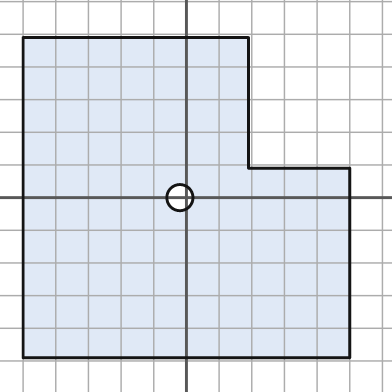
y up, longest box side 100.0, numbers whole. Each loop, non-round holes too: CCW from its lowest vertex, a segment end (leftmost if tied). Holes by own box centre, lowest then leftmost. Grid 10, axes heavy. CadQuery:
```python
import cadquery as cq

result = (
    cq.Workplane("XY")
    .moveTo(-50.0, -49.0)
    .lineTo(50.0, -49.0)
    .lineTo(50.0, 9.0)
    .lineTo(19.0, 9.0)
    .lineTo(19.0, 49.0)
    .lineTo(-50.0, 49.0)
    .close()
    .moveTo(-2.0, 0.0)
    .circle(4.0)
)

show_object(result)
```